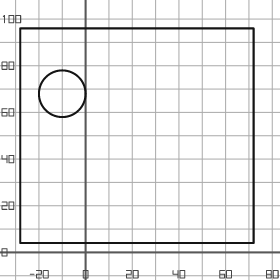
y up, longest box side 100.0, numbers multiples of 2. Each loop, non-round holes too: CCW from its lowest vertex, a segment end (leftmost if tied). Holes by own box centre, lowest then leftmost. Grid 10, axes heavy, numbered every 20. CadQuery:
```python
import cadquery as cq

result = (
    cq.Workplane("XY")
    .moveTo(-28.0, 4.0)
    .lineTo(72.0, 4.0)
    .lineTo(72.0, 96.0)
    .lineTo(-28.0, 96.0)
    .close()
    .moveTo(-10.0, 68.0)
    .circle(10.0)
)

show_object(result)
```